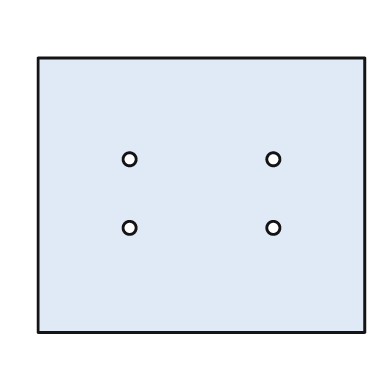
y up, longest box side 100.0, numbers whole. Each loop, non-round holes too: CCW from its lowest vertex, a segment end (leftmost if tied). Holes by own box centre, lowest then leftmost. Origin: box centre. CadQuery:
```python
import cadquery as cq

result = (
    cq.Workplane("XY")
    .moveTo(-50.0, -42.0)
    .lineTo(50.0, -42.0)
    .lineTo(50.0, 42.0)
    .lineTo(-50.0, 42.0)
    .close()
    .moveTo(-22.0, -10.0)
    .circle(2.0)
    .moveTo(22.0, -10.0)
    .circle(2.0)
    .moveTo(-22.0, 11.0)
    .circle(2.0)
    .moveTo(22.0, 11.0)
    .circle(2.0)
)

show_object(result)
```